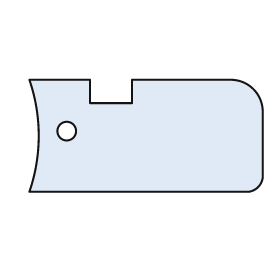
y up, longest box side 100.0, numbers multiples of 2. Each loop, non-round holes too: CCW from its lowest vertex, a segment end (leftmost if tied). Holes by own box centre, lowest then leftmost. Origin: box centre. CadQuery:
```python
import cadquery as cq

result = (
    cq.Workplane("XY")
    .moveTo(-50.0, -24.0)
    .lineTo(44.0, -24.0)
    .threePointArc((48.0, -22.0), (50.0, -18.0))
    .lineTo(50.0, 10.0)
    .threePointArc((46.0, 20.0), (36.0, 24.0))
    .lineTo(-6.0, 24.0)
    .lineTo(-6.0, 14.0)
    .lineTo(-24.0, 14.0)
    .lineTo(-24.0, 24.0)
    .lineTo(-50.0, 24.0)
    .threePointArc((-46.0, 0.0), (-50.0, -24.0))
    .close()
    .moveTo(-34.0, 2.0)
    .circle(4.0)
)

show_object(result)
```